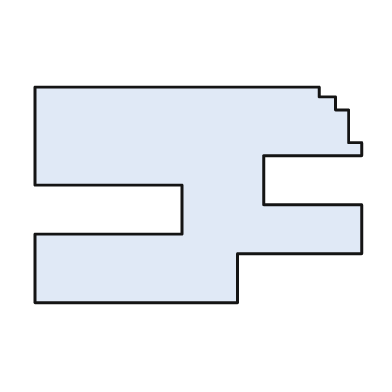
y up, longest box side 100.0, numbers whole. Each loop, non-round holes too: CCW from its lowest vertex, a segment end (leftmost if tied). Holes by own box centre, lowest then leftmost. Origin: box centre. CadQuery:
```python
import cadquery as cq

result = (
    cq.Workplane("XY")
    .moveTo(-50.0, -33.0)
    .lineTo(12.0, -33.0)
    .lineTo(12.0, -18.0)
    .lineTo(50.0, -18.0)
    .lineTo(50.0, -3.0)
    .lineTo(20.0, -3.0)
    .lineTo(20.0, 12.0)
    .lineTo(50.0, 12.0)
    .lineTo(50.0, 16.0)
    .lineTo(46.0, 16.0)
    .lineTo(46.0, 26.0)
    .lineTo(42.0, 26.0)
    .lineTo(42.0, 30.0)
    .lineTo(37.0, 30.0)
    .lineTo(37.0, 33.0)
    .lineTo(-50.0, 33.0)
    .lineTo(-50.0, 3.0)
    .lineTo(-5.0, 3.0)
    .lineTo(-5.0, -12.0)
    .lineTo(-50.0, -12.0)
    .close()
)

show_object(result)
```